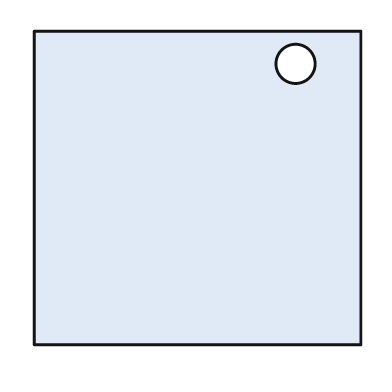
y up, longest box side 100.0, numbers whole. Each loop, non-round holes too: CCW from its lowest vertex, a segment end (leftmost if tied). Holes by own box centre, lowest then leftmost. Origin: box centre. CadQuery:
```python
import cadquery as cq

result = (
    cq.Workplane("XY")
    .moveTo(-50.0, -48.0)
    .lineTo(50.0, -48.0)
    .lineTo(50.0, 48.0)
    .lineTo(-50.0, 48.0)
    .close()
    .moveTo(30.0, 38.0)
    .circle(6.0)
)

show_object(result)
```